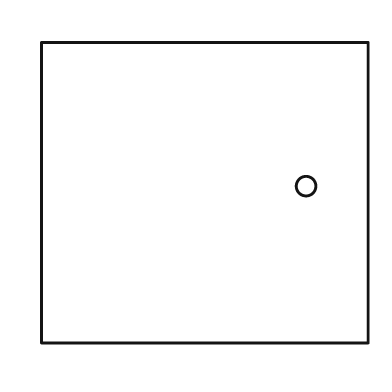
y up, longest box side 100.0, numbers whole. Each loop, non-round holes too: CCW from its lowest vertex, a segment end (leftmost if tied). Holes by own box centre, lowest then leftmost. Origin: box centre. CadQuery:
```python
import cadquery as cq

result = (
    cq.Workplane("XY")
    .moveTo(-50.0, -46.0)
    .lineTo(50.0, -46.0)
    .lineTo(50.0, 46.0)
    .lineTo(-50.0, 46.0)
    .close()
    .moveTo(31.0, 2.0)
    .circle(3.0)
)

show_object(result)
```